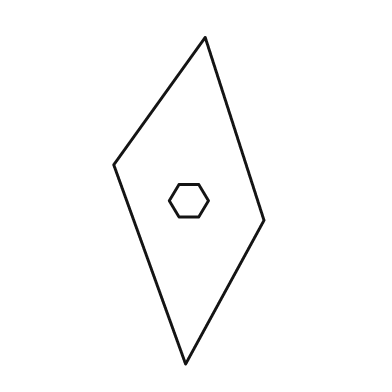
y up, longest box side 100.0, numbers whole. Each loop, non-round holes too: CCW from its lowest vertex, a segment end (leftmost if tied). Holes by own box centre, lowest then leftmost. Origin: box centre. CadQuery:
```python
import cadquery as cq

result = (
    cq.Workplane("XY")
    .moveTo(-1.0, -50.0)
    .lineTo(23.0, -6.0)
    .lineTo(5.0, 50.0)
    .lineTo(-23.0, 11.0)
    .close()
    .moveTo(-3.0, -5.0)
    .lineTo(3.0, -5.0)
    .lineTo(6.0, 0.0)
    .lineTo(3.0, 5.0)
    .lineTo(-3.0, 5.0)
    .lineTo(-6.0, 0.0)
    .close()
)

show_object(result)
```